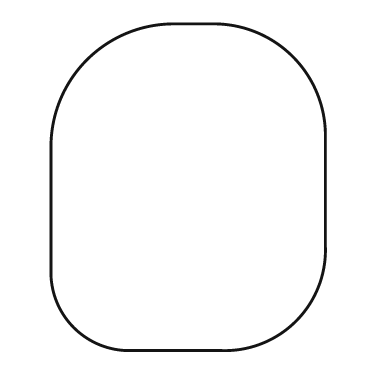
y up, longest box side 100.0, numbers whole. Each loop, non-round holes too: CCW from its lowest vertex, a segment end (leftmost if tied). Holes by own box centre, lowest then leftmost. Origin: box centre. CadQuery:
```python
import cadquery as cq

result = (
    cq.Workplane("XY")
    .moveTo(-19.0, -50.0)
    .lineTo(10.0, -50.0)
    .threePointArc((33.0, -41.0), (42.0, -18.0))
    .lineTo(42.0, 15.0)
    .threePointArc((32.0, 40.0), (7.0, 50.0))
    .lineTo(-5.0, 50.0)
    .threePointArc((-31.0, 39.0), (-42.0, 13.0))
    .lineTo(-42.0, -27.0)
    .threePointArc((-35.0, -43.0), (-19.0, -50.0))
    .close()
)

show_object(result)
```